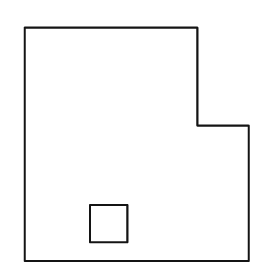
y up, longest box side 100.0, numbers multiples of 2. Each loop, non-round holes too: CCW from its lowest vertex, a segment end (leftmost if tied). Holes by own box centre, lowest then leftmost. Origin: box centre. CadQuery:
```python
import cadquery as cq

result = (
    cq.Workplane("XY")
    .moveTo(-48.0, -50.0)
    .lineTo(48.0, -50.0)
    .lineTo(48.0, 8.0)
    .lineTo(26.0, 8.0)
    .lineTo(26.0, 50.0)
    .lineTo(-48.0, 50.0)
    .close()
    .moveTo(-20.0, -42.0)
    .lineTo(-4.0, -42.0)
    .lineTo(-4.0, -26.0)
    .lineTo(-20.0, -26.0)
    .close()
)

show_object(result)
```